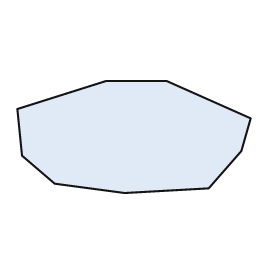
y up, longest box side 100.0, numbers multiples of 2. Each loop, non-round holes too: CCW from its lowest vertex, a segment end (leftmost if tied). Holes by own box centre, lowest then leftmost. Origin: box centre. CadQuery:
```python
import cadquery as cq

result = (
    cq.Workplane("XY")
    .moveTo(-4.0, -24.0)
    .lineTo(32.0, -22.0)
    .lineTo(46.0, -6.0)
    .lineTo(50.0, 8.0)
    .lineTo(14.0, 24.0)
    .lineTo(-12.0, 24.0)
    .lineTo(-50.0, 12.0)
    .lineTo(-48.0, -8.0)
    .lineTo(-34.0, -20.0)
    .close()
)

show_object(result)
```